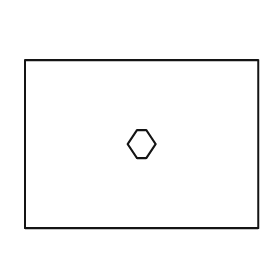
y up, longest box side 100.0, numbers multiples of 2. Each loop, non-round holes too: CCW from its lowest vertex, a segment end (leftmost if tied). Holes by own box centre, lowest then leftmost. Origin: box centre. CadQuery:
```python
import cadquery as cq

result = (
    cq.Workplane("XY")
    .moveTo(-50.0, -36.0)
    .lineTo(50.0, -36.0)
    .lineTo(50.0, 36.0)
    .lineTo(-50.0, 36.0)
    .close()
    .moveTo(-2.0, -6.0)
    .lineTo(2.0, -6.0)
    .lineTo(6.0, 0.0)
    .lineTo(2.0, 6.0)
    .lineTo(-2.0, 6.0)
    .lineTo(-6.0, 0.0)
    .close()
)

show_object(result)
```